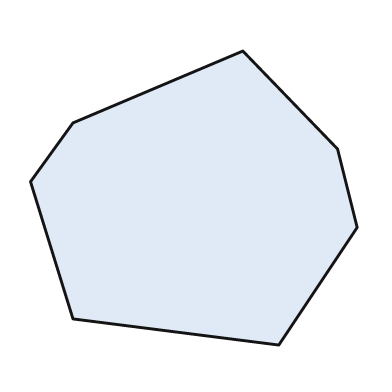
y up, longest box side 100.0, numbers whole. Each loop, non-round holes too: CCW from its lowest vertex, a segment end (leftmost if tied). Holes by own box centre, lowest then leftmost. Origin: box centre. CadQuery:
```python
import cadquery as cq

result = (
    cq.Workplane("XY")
    .moveTo(26.0, -45.0)
    .lineTo(50.0, -9.0)
    .lineTo(44.0, 15.0)
    .lineTo(15.0, 45.0)
    .lineTo(-37.0, 23.0)
    .lineTo(-50.0, 5.0)
    .lineTo(-37.0, -37.0)
    .close()
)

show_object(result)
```